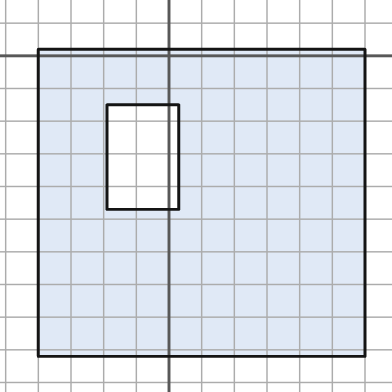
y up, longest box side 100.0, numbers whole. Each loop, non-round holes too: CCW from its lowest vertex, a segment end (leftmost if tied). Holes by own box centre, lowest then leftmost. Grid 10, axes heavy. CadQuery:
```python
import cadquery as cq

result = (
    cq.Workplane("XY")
    .moveTo(-40.0, -92.0)
    .lineTo(60.0, -92.0)
    .lineTo(60.0, 2.0)
    .lineTo(-40.0, 2.0)
    .close()
    .moveTo(-19.0, -47.0)
    .lineTo(3.0, -47.0)
    .lineTo(3.0, -15.0)
    .lineTo(-19.0, -15.0)
    .close()
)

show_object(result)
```